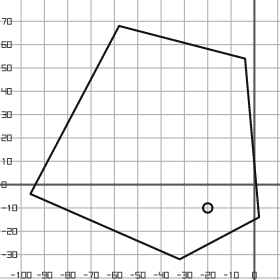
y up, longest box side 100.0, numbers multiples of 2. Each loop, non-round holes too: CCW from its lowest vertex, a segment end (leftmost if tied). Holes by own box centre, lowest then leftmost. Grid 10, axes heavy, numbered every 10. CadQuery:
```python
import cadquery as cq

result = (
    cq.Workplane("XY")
    .moveTo(-32.0, -32.0)
    .lineTo(2.0, -14.0)
    .lineTo(-4.0, 54.0)
    .lineTo(-58.0, 68.0)
    .lineTo(-96.0, -4.0)
    .close()
    .moveTo(-20.0, -10.0)
    .circle(2.0)
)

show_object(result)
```